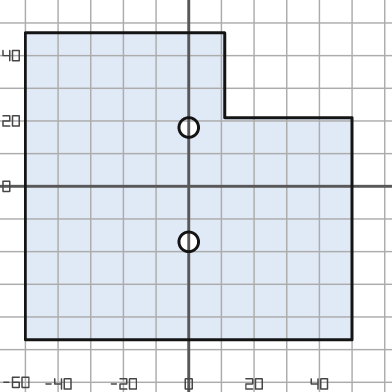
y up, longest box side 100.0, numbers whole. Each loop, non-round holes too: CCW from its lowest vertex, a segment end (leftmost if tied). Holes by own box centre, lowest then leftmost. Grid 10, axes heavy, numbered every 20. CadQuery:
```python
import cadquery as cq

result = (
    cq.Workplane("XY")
    .moveTo(-50.0, -47.0)
    .lineTo(50.0, -47.0)
    .lineTo(50.0, 21.0)
    .lineTo(11.0, 21.0)
    .lineTo(11.0, 47.0)
    .lineTo(-50.0, 47.0)
    .close()
    .moveTo(0.0, -17.0)
    .circle(3.0)
    .moveTo(0.0, 18.0)
    .circle(3.0)
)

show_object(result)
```